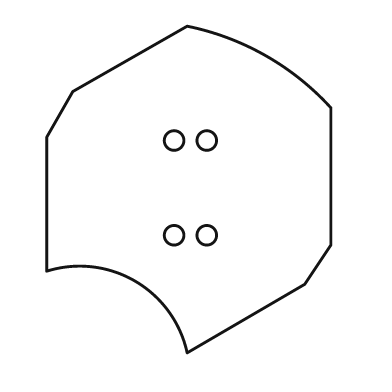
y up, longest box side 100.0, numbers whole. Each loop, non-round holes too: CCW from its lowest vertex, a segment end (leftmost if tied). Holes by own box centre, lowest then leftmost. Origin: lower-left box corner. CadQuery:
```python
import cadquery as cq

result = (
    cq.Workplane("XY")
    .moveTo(43.0, 0.0)
    .lineTo(79.0, 21.0)
    .lineTo(87.0, 33.0)
    .lineTo(87.0, 75.0)
    .threePointArc((67.0, 91.0), (43.0, 100.0))
    .lineTo(8.0, 80.0)
    .lineTo(0.0, 66.0)
    .lineTo(0.0, 25.0)
    .threePointArc((27.0, 22.0), (43.0, 0.0))
    .close()
    .moveTo(39.0, 36.0)
    .circle(3.0)
    .moveTo(49.0, 36.0)
    .circle(3.0)
    .moveTo(39.0, 65.0)
    .circle(3.0)
    .moveTo(49.0, 65.0)
    .circle(3.0)
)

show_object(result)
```